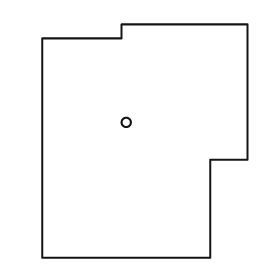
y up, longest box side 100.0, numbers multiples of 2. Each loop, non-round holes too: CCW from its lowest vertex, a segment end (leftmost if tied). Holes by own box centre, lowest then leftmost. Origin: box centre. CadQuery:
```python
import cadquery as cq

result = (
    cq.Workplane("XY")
    .moveTo(-44.0, -50.0)
    .lineTo(28.0, -50.0)
    .lineTo(28.0, -8.0)
    .lineTo(44.0, -8.0)
    .lineTo(44.0, 50.0)
    .lineTo(-10.0, 50.0)
    .lineTo(-10.0, 44.0)
    .lineTo(-44.0, 44.0)
    .close()
    .moveTo(-8.0, 8.0)
    .circle(2.0)
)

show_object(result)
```